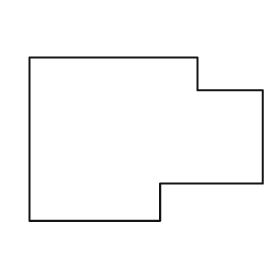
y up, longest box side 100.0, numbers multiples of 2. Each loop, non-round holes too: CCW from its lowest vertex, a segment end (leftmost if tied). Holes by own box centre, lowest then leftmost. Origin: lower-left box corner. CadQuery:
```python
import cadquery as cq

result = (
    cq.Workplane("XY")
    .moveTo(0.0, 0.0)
    .lineTo(56.0, 0.0)
    .lineTo(56.0, 16.0)
    .lineTo(100.0, 16.0)
    .lineTo(100.0, 56.0)
    .lineTo(72.0, 56.0)
    .lineTo(72.0, 70.0)
    .lineTo(0.0, 70.0)
    .close()
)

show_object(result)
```